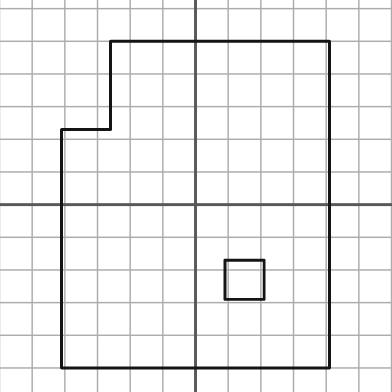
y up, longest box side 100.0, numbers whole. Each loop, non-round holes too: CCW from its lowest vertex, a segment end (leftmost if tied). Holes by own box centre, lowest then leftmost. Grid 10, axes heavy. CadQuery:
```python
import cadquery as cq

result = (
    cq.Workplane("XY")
    .moveTo(-41.0, -50.0)
    .lineTo(41.0, -50.0)
    .lineTo(41.0, 50.0)
    .lineTo(-26.0, 50.0)
    .lineTo(-26.0, 23.0)
    .lineTo(-41.0, 23.0)
    .close()
    .moveTo(9.0, -29.0)
    .lineTo(21.0, -29.0)
    .lineTo(21.0, -17.0)
    .lineTo(9.0, -17.0)
    .close()
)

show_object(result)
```